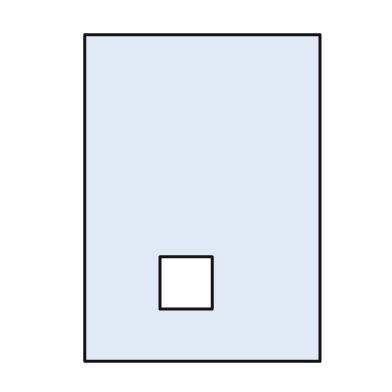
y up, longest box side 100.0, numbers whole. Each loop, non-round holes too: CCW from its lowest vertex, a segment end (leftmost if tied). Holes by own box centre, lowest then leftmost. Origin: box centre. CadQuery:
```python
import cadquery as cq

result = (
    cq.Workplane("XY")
    .moveTo(-36.0, -50.0)
    .lineTo(36.0, -50.0)
    .lineTo(36.0, 50.0)
    .lineTo(-36.0, 50.0)
    .close()
    .moveTo(-13.0, -34.0)
    .lineTo(3.0, -34.0)
    .lineTo(3.0, -18.0)
    .lineTo(-13.0, -18.0)
    .close()
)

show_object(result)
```